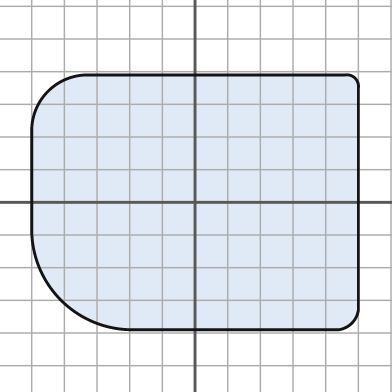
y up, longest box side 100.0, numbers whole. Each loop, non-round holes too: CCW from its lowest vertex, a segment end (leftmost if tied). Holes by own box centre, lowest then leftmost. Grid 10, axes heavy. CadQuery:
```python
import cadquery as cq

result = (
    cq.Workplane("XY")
    .moveTo(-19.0, -39.0)
    .lineTo(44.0, -39.0)
    .threePointArc((48.0, -37.0), (50.0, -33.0))
    .lineTo(50.0, 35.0)
    .threePointArc((49.0, 38.0), (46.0, 39.0))
    .lineTo(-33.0, 39.0)
    .threePointArc((-45.0, 34.0), (-50.0, 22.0))
    .lineTo(-50.0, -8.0)
    .threePointArc((-41.0, -30.0), (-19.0, -39.0))
    .close()
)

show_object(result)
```